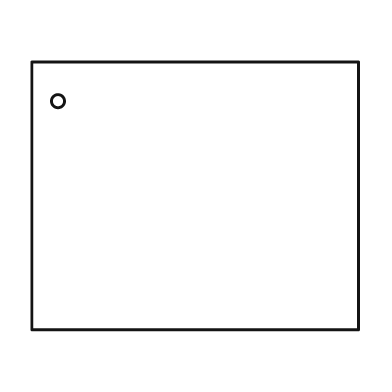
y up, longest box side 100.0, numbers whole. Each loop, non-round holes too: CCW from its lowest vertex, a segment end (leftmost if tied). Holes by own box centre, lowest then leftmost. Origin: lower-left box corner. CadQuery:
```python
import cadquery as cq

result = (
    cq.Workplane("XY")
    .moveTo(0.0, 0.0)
    .lineTo(100.0, 0.0)
    .lineTo(100.0, 82.0)
    .lineTo(0.0, 82.0)
    .close()
    .moveTo(8.0, 70.0)
    .circle(2.0)
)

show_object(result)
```